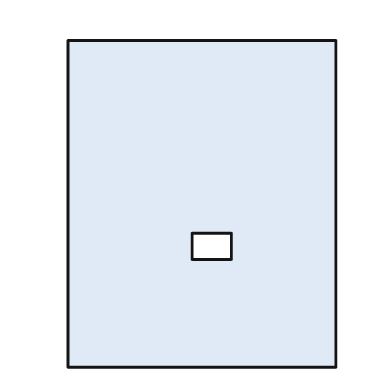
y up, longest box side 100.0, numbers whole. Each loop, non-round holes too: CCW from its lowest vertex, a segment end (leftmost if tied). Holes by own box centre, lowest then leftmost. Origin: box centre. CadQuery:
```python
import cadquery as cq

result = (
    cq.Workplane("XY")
    .moveTo(-41.0, -50.0)
    .lineTo(41.0, -50.0)
    .lineTo(41.0, 50.0)
    .lineTo(-41.0, 50.0)
    .close()
    .moveTo(-3.0, -17.0)
    .lineTo(9.0, -17.0)
    .lineTo(9.0, -9.0)
    .lineTo(-3.0, -9.0)
    .close()
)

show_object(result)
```